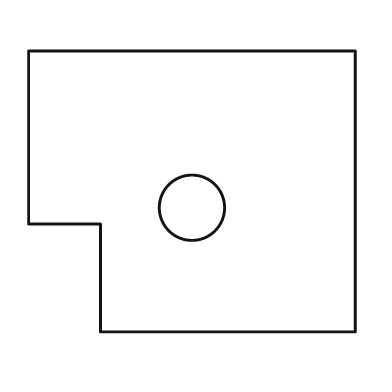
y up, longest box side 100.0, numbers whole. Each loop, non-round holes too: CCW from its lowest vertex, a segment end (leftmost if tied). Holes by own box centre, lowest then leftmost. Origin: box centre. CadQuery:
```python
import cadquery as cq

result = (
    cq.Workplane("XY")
    .moveTo(-28.0, -43.0)
    .lineTo(50.0, -43.0)
    .lineTo(50.0, 43.0)
    .lineTo(-50.0, 43.0)
    .lineTo(-50.0, -10.0)
    .lineTo(-28.0, -10.0)
    .close()
    .moveTo(0.0, -5.0)
    .circle(10.0)
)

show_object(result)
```